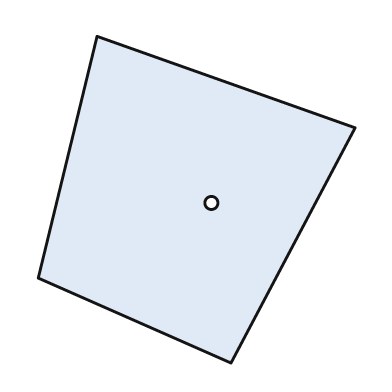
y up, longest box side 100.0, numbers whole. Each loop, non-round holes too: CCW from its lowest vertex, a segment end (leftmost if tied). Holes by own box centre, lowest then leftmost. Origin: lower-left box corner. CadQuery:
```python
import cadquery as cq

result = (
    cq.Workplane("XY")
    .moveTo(59.0, 0.0)
    .lineTo(97.0, 72.0)
    .lineTo(18.0, 100.0)
    .lineTo(0.0, 26.0)
    .close()
    .moveTo(53.0, 49.0)
    .circle(2.0)
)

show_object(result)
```